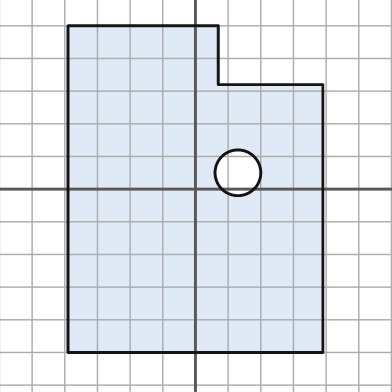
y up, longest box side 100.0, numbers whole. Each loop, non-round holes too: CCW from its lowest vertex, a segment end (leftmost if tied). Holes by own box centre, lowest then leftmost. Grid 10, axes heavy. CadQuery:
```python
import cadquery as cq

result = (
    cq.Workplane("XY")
    .moveTo(-39.0, -50.0)
    .lineTo(39.0, -50.0)
    .lineTo(39.0, 32.0)
    .lineTo(7.0, 32.0)
    .lineTo(7.0, 50.0)
    .lineTo(-39.0, 50.0)
    .close()
    .moveTo(13.0, 5.0)
    .circle(7.0)
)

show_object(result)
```